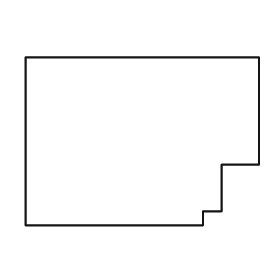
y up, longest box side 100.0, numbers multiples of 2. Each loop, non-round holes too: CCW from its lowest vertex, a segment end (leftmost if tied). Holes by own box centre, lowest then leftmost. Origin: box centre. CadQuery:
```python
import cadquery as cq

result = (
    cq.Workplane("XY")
    .moveTo(-50.0, -36.0)
    .lineTo(26.0, -36.0)
    .lineTo(26.0, -30.0)
    .lineTo(34.0, -30.0)
    .lineTo(34.0, -10.0)
    .lineTo(50.0, -10.0)
    .lineTo(50.0, 36.0)
    .lineTo(-50.0, 36.0)
    .close()
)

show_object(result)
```